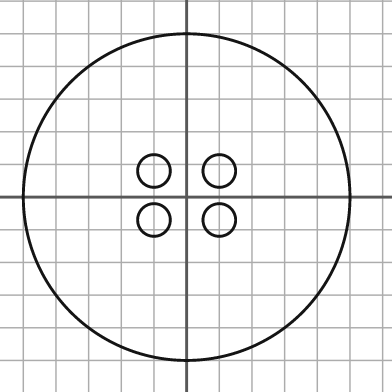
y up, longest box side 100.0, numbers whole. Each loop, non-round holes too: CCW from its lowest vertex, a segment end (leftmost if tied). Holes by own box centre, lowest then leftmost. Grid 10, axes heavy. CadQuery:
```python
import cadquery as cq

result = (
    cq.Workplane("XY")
    .moveTo(0.0, 0.0)
    .circle(50.0)
    .moveTo(-10.0, -7.0)
    .circle(5.0)
    .moveTo(10.0, -7.0)
    .circle(5.0)
    .moveTo(-10.0, 8.0)
    .circle(5.0)
    .moveTo(10.0, 8.0)
    .circle(5.0)
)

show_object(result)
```